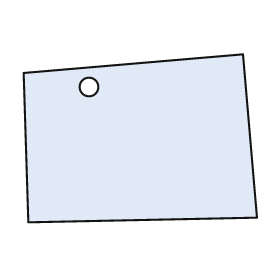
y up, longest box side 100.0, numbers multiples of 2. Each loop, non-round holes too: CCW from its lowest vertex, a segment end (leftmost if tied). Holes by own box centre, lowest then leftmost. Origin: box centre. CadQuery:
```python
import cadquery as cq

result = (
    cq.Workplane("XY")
    .moveTo(-48.0, -36.0)
    .lineTo(50.0, -34.0)
    .lineTo(44.0, 36.0)
    .lineTo(-50.0, 28.0)
    .close()
    .moveTo(-22.0, 22.0)
    .circle(4.0)
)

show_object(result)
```